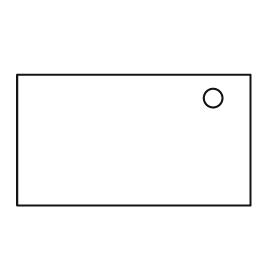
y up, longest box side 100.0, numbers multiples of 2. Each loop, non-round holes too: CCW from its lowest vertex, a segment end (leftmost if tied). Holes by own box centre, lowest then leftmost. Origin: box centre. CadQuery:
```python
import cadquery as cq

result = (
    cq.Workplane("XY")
    .moveTo(-50.0, -28.0)
    .lineTo(50.0, -28.0)
    .lineTo(50.0, 28.0)
    .lineTo(-50.0, 28.0)
    .close()
    .moveTo(34.0, 18.0)
    .circle(4.0)
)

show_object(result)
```